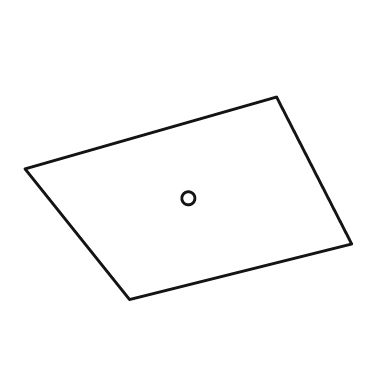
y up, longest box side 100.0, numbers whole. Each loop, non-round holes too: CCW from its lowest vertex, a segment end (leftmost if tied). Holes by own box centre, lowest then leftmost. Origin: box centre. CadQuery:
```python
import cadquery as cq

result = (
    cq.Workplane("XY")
    .moveTo(-18.0, -31.0)
    .lineTo(50.0, -14.0)
    .lineTo(27.0, 31.0)
    .lineTo(-50.0, 9.0)
    .close()
    .moveTo(0.0, 0.0)
    .circle(2.0)
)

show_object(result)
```